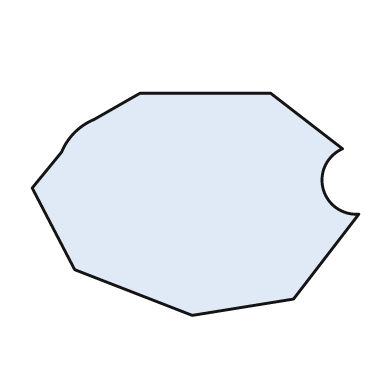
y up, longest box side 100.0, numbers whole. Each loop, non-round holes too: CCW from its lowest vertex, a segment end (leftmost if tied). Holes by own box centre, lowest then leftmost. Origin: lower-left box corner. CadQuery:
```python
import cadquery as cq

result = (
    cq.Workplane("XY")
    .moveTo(49.0, 0.0)
    .lineTo(80.0, 5.0)
    .lineTo(100.0, 31.0)
    .threePointArc((89.0, 39.0), (95.0, 51.0))
    .lineTo(73.0, 68.0)
    .lineTo(33.0, 68.0)
    .lineTo(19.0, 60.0)
    .threePointArc((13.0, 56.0), (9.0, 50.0))
    .lineTo(0.0, 39.0)
    .lineTo(13.0, 14.0)
    .close()
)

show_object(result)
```